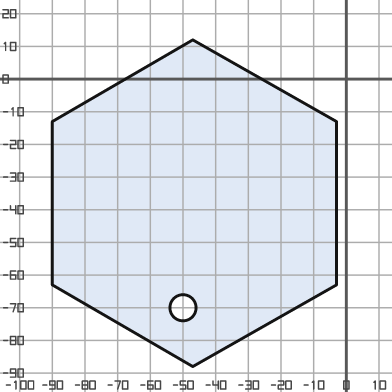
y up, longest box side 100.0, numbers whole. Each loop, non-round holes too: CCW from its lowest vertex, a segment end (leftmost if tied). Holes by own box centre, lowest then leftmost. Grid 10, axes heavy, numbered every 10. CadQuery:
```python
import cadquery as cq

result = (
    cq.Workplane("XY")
    .moveTo(-47.0, -88.0)
    .lineTo(-3.0, -63.0)
    .lineTo(-3.0, -13.0)
    .lineTo(-47.0, 12.0)
    .lineTo(-90.0, -13.0)
    .lineTo(-90.0, -63.0)
    .close()
    .moveTo(-50.0, -70.0)
    .circle(4.0)
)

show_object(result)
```